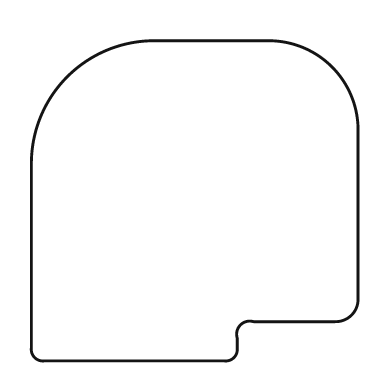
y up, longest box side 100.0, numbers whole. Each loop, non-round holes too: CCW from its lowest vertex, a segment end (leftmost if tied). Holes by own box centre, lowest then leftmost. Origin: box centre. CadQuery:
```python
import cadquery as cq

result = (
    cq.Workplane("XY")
    .moveTo(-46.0, -49.0)
    .lineTo(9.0, -49.0)
    .threePointArc((12.0, -48.0), (13.0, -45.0))
    .lineTo(13.0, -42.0)
    .threePointArc((14.0, -38.0), (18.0, -37.0))
    .lineTo(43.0, -37.0)
    .threePointArc((48.0, -35.0), (50.0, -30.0))
    .lineTo(50.0, 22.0)
    .threePointArc((42.0, 41.0), (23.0, 49.0))
    .lineTo(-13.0, 49.0)
    .threePointArc((-39.0, 38.0), (-50.0, 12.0))
    .lineTo(-50.0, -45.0)
    .threePointArc((-49.0, -48.0), (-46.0, -49.0))
    .close()
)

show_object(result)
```